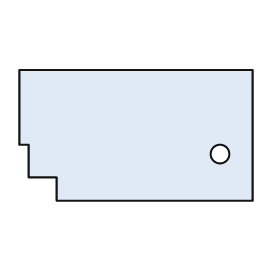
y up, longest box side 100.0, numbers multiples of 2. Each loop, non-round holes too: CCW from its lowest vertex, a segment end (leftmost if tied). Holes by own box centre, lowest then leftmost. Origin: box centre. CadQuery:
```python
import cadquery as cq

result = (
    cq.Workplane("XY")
    .moveTo(-34.0, -28.0)
    .lineTo(50.0, -28.0)
    .lineTo(50.0, 28.0)
    .lineTo(-50.0, 28.0)
    .lineTo(-50.0, -4.0)
    .lineTo(-46.0, -4.0)
    .lineTo(-46.0, -18.0)
    .lineTo(-34.0, -18.0)
    .close()
    .moveTo(36.0, -8.0)
    .circle(4.0)
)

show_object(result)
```